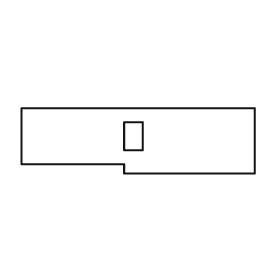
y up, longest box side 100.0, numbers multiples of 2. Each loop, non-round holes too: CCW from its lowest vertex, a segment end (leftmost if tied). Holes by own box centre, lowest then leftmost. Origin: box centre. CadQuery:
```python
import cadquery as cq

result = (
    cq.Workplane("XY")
    .moveTo(-6.0, -14.0)
    .lineTo(50.0, -14.0)
    .lineTo(50.0, 14.0)
    .lineTo(-50.0, 14.0)
    .lineTo(-50.0, -10.0)
    .lineTo(-6.0, -10.0)
    .close()
    .moveTo(-6.0, -4.0)
    .lineTo(2.0, -4.0)
    .lineTo(2.0, 8.0)
    .lineTo(-6.0, 8.0)
    .close()
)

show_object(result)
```